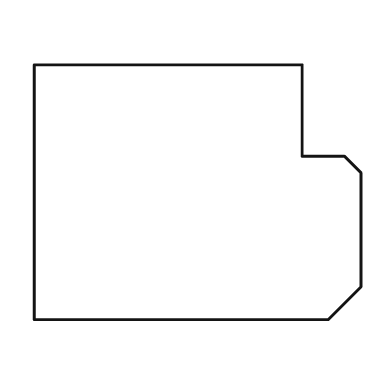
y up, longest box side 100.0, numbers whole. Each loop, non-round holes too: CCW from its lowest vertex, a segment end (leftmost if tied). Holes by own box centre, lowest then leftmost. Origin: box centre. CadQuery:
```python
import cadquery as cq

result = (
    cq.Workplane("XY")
    .moveTo(-50.0, -39.0)
    .lineTo(40.0, -39.0)
    .lineTo(50.0, -29.0)
    .lineTo(50.0, 6.0)
    .lineTo(45.0, 11.0)
    .lineTo(32.0, 11.0)
    .lineTo(32.0, 39.0)
    .lineTo(-50.0, 39.0)
    .close()
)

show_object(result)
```